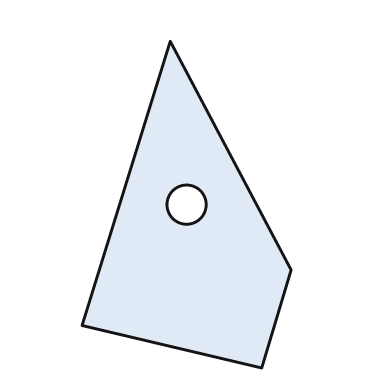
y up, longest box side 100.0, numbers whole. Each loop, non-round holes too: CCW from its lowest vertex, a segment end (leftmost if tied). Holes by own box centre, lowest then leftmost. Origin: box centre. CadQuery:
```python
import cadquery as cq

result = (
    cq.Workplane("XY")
    .moveTo(23.0, -50.0)
    .lineTo(32.0, -20.0)
    .lineTo(-5.0, 50.0)
    .lineTo(-32.0, -37.0)
    .close()
    .moveTo(0.0, 0.0)
    .circle(6.0)
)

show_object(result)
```